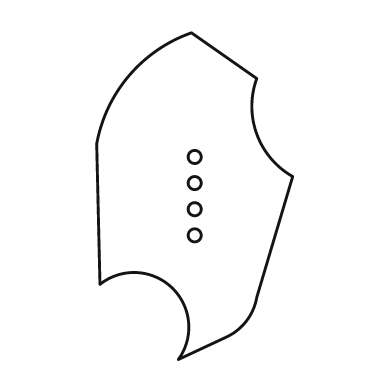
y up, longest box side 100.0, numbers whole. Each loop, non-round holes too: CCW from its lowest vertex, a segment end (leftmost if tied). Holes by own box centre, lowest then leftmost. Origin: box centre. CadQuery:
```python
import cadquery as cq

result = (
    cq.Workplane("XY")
    .moveTo(-5.0, -50.0)
    .lineTo(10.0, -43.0)
    .threePointArc((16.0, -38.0), (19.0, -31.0))
    .lineTo(30.0, 6.0)
    .threePointArc((19.0, 19.0), (19.0, 36.0))
    .lineTo(-1.0, 50.0)
    .threePointArc((-20.0, 37.0), (-30.0, 16.0))
    .lineTo(-29.0, -27.0)
    .threePointArc((-7.0, -28.0), (-5.0, -50.0))
    .close()
    .moveTo(0.0, -12.0)
    .circle(2.0)
    .moveTo(0.0, -4.0)
    .circle(2.0)
    .moveTo(0.0, 4.0)
    .circle(2.0)
    .moveTo(0.0, 12.0)
    .circle(2.0)
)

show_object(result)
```